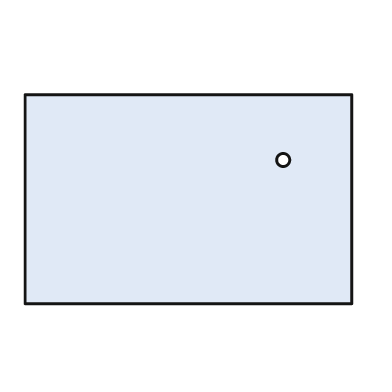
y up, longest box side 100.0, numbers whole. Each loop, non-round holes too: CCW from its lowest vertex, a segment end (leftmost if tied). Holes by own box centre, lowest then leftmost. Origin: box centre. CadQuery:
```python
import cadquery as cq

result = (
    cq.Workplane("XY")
    .moveTo(-50.0, -32.0)
    .lineTo(50.0, -32.0)
    .lineTo(50.0, 32.0)
    .lineTo(-50.0, 32.0)
    .close()
    .moveTo(29.0, 12.0)
    .circle(2.0)
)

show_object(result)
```